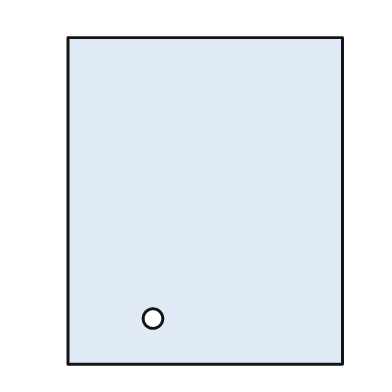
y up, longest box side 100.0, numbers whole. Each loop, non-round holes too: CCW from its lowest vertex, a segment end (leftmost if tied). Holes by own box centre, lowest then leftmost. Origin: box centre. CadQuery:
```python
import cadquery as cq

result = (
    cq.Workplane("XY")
    .moveTo(-42.0, -50.0)
    .lineTo(42.0, -50.0)
    .lineTo(42.0, 50.0)
    .lineTo(-42.0, 50.0)
    .close()
    .moveTo(-16.0, -36.0)
    .circle(3.0)
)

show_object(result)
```